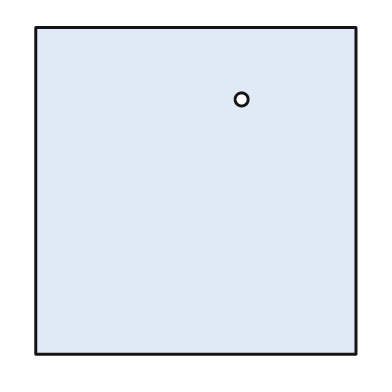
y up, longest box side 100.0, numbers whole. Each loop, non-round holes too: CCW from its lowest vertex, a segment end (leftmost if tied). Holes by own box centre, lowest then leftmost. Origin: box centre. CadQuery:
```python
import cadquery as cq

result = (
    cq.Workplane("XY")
    .moveTo(-49.0, -50.0)
    .lineTo(49.0, -50.0)
    .lineTo(49.0, 50.0)
    .lineTo(-49.0, 50.0)
    .close()
    .moveTo(14.0, 28.0)
    .circle(2.0)
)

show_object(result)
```